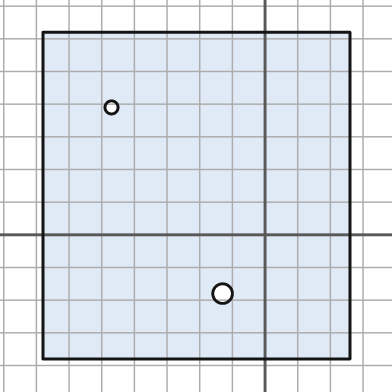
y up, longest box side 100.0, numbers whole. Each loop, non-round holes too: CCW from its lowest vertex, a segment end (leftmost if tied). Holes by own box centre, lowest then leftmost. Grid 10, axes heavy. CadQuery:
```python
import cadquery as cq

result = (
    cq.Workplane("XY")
    .moveTo(-68.0, -38.0)
    .lineTo(26.0, -38.0)
    .lineTo(26.0, 62.0)
    .lineTo(-68.0, 62.0)
    .close()
    .moveTo(-13.0, -18.0)
    .circle(3.0)
    .moveTo(-47.0, 39.0)
    .circle(2.0)
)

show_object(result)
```